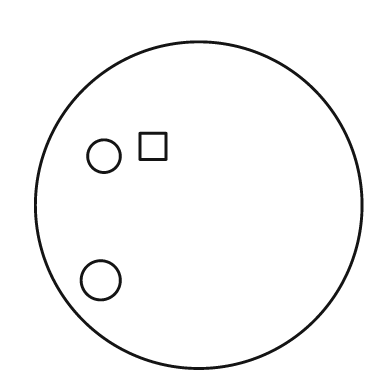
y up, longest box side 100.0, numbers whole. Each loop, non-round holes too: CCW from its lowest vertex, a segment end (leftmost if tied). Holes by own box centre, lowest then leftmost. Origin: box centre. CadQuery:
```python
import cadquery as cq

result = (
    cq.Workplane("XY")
    .moveTo(0.0, 0.0)
    .circle(50.0)
    .moveTo(-30.0, -23.0)
    .circle(6.0)
    .moveTo(-29.0, 15.0)
    .circle(5.0)
    .moveTo(-18.0, 14.0)
    .lineTo(-10.0, 14.0)
    .lineTo(-10.0, 22.0)
    .lineTo(-18.0, 22.0)
    .close()
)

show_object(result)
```